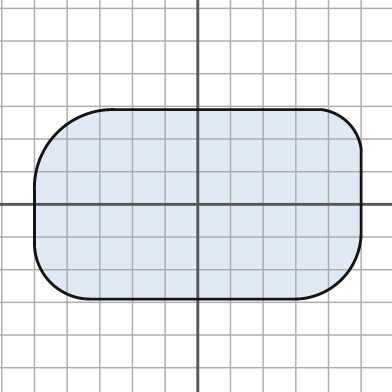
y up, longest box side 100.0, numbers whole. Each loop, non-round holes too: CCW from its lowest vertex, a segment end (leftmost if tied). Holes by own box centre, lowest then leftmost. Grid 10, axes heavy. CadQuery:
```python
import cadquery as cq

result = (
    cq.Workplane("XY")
    .moveTo(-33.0, -29.0)
    .lineTo(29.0, -29.0)
    .threePointArc((44.0, -23.0), (50.0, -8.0))
    .lineTo(50.0, 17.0)
    .threePointArc((46.0, 25.0), (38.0, 29.0))
    .lineTo(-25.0, 29.0)
    .threePointArc((-43.0, 22.0), (-50.0, 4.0))
    .lineTo(-50.0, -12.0)
    .threePointArc((-45.0, -24.0), (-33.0, -29.0))
    .close()
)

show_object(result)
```